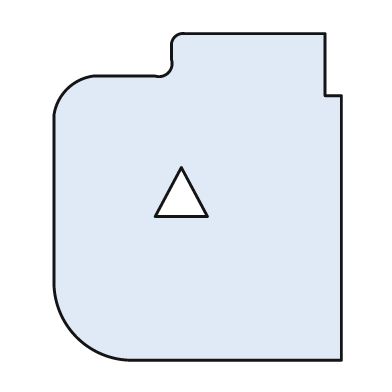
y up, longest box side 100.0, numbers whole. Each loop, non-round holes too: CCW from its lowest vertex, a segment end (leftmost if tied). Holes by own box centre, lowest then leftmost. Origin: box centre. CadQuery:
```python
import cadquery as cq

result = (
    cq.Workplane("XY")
    .moveTo(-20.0, -50.0)
    .lineTo(44.0, -50.0)
    .lineTo(44.0, 31.0)
    .lineTo(39.0, 31.0)
    .lineTo(39.0, 50.0)
    .lineTo(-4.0, 50.0)
    .threePointArc((-7.0, 49.0), (-8.0, 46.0))
    .lineTo(-8.0, 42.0)
    .threePointArc((-9.0, 38.0), (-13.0, 37.0))
    .lineTo(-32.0, 37.0)
    .threePointArc((-40.0, 33.0), (-44.0, 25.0))
    .lineTo(-44.0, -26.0)
    .threePointArc((-37.0, -43.0), (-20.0, -50.0))
    .close()
    .moveTo(-13.0, -6.0)
    .lineTo(3.0, -6.0)
    .lineTo(-5.0, 9.0)
    .close()
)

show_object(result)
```